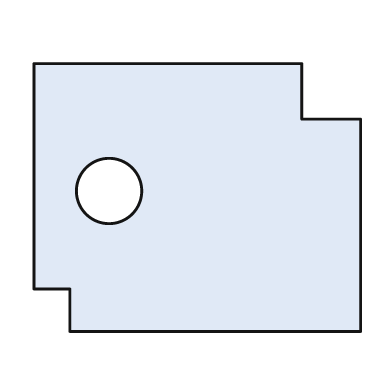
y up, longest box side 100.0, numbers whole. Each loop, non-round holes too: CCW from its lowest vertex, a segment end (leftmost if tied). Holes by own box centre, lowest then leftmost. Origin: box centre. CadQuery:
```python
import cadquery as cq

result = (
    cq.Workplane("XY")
    .moveTo(-39.0, -41.0)
    .lineTo(50.0, -41.0)
    .lineTo(50.0, 24.0)
    .lineTo(32.0, 24.0)
    .lineTo(32.0, 41.0)
    .lineTo(-50.0, 41.0)
    .lineTo(-50.0, -28.0)
    .lineTo(-39.0, -28.0)
    .close()
    .moveTo(-27.0, 2.0)
    .circle(10.0)
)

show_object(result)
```